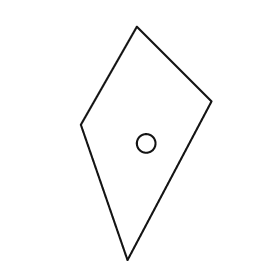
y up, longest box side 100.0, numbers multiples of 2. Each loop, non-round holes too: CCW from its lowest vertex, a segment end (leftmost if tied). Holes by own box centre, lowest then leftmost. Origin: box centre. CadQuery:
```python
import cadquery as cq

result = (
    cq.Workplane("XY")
    .moveTo(-8.0, -50.0)
    .lineTo(28.0, 18.0)
    .lineTo(-4.0, 50.0)
    .lineTo(-28.0, 8.0)
    .close()
    .moveTo(0.0, 0.0)
    .circle(4.0)
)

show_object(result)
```